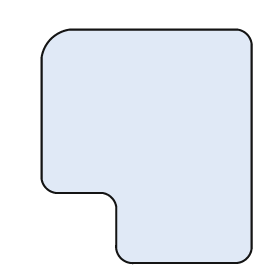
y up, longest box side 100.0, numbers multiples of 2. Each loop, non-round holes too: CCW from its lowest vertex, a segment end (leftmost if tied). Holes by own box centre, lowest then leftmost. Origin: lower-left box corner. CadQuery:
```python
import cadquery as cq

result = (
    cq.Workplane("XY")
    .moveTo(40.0, 0.0)
    .lineTo(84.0, 0.0)
    .threePointArc((88.0, 2.0), (90.0, 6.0))
    .lineTo(90.0, 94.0)
    .threePointArc((88.0, 98.0), (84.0, 100.0))
    .lineTo(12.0, 100.0)
    .threePointArc((4.0, 96.0), (0.0, 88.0))
    .lineTo(0.0, 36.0)
    .threePointArc((2.0, 32.0), (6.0, 30.0))
    .lineTo(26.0, 30.0)
    .threePointArc((30.0, 28.0), (32.0, 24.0))
    .lineTo(32.0, 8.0)
    .threePointArc((34.0, 2.0), (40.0, 0.0))
    .close()
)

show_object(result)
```